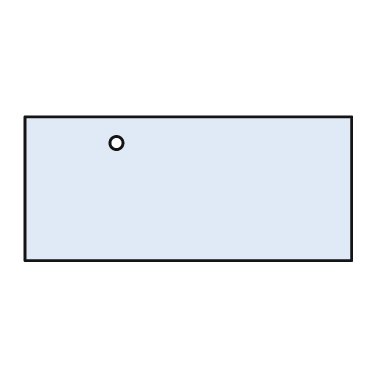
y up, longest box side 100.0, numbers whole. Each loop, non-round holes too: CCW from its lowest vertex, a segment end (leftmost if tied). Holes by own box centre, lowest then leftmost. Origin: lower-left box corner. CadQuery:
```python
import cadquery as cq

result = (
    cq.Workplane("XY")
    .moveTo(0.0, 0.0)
    .lineTo(100.0, 0.0)
    .lineTo(100.0, 44.0)
    .lineTo(0.0, 44.0)
    .close()
    .moveTo(28.0, 36.0)
    .circle(2.0)
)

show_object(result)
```